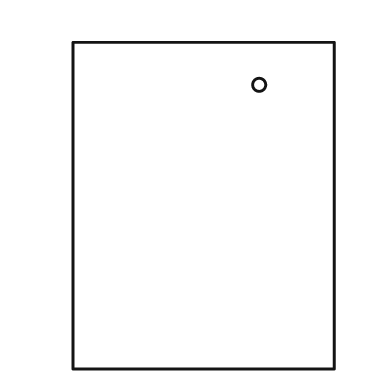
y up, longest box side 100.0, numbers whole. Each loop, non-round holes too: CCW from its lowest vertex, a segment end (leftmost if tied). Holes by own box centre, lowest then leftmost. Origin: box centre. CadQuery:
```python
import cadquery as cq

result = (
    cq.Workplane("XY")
    .moveTo(-40.0, -50.0)
    .lineTo(40.0, -50.0)
    .lineTo(40.0, 50.0)
    .lineTo(-40.0, 50.0)
    .close()
    .moveTo(17.0, 37.0)
    .circle(2.0)
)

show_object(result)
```